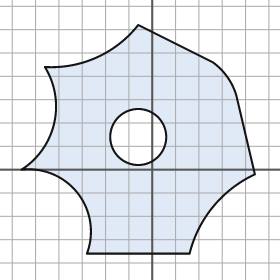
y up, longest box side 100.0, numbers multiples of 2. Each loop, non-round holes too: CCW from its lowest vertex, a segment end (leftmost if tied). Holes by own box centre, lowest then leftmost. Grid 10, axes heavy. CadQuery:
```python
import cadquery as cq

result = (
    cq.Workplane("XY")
    .moveTo(-28.0, -36.0)
    .lineTo(16.0, -36.0)
    .threePointArc((26.0, -16.0), (44.0, -2.0))
    .lineTo(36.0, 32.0)
    .threePointArc((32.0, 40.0), (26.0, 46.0))
    .lineTo(-6.0, 62.0)
    .threePointArc((-24.0, 48.0), (-46.0, 44.0))
    .threePointArc((-42.0, 20.0), (-56.0, 0.0))
    .threePointArc((-32.0, -10.0), (-28.0, -36.0))
    .close()
    .moveTo(-6.0, 14.0)
    .circle(12.0)
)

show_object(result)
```